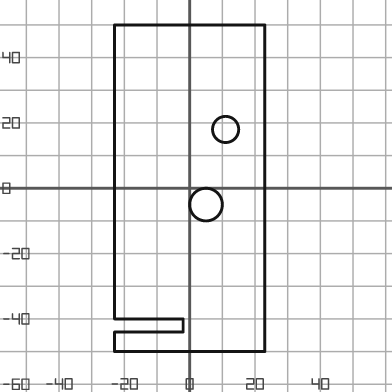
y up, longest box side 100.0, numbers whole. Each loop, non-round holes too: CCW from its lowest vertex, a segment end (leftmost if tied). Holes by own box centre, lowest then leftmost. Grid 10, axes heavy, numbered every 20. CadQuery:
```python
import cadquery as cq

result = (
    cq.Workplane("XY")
    .moveTo(-23.0, -50.0)
    .lineTo(23.0, -50.0)
    .lineTo(23.0, 50.0)
    .lineTo(-23.0, 50.0)
    .lineTo(-23.0, -40.0)
    .lineTo(-2.0, -40.0)
    .lineTo(-2.0, -44.0)
    .lineTo(-23.0, -44.0)
    .close()
    .moveTo(5.0, -5.0)
    .circle(5.0)
    .moveTo(11.0, 18.0)
    .circle(4.0)
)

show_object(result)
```